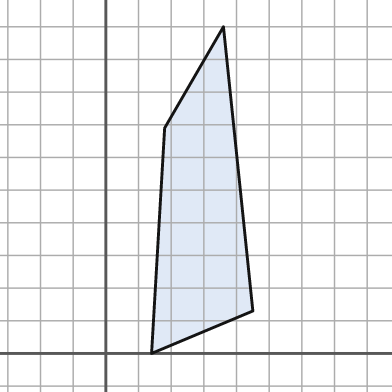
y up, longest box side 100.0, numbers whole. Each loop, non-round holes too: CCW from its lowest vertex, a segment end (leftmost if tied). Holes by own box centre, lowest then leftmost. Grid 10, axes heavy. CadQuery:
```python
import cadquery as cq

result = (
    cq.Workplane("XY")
    .moveTo(14.0, 0.0)
    .lineTo(45.0, 13.0)
    .lineTo(36.0, 100.0)
    .lineTo(18.0, 69.0)
    .close()
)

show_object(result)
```